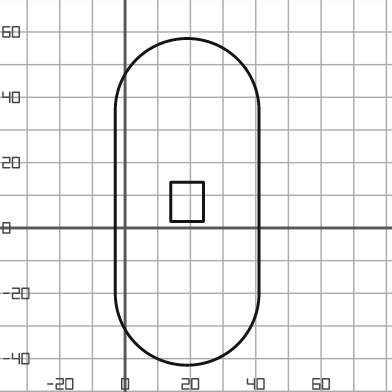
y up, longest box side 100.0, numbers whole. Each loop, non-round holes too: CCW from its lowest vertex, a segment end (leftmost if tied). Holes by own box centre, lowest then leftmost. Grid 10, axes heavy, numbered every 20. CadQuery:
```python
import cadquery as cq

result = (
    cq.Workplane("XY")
    .moveTo(-3.0, -20.0)
    .threePointArc((19.0, -42.0), (41.0, -20.0))
    .lineTo(41.0, 36.0)
    .threePointArc((19.0, 58.0), (-3.0, 36.0))
    .close()
    .moveTo(14.0, 2.0)
    .lineTo(24.0, 2.0)
    .lineTo(24.0, 14.0)
    .lineTo(14.0, 14.0)
    .close()
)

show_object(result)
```